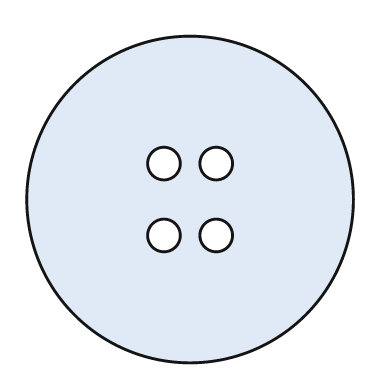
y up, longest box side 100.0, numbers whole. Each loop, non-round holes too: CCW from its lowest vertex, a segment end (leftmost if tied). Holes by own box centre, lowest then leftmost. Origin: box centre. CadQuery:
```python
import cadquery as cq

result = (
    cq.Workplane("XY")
    .moveTo(0.0, 0.0)
    .circle(50.0)
    .moveTo(-8.0, -11.0)
    .circle(5.0)
    .moveTo(8.0, -11.0)
    .circle(5.0)
    .moveTo(-8.0, 11.0)
    .circle(5.0)
    .moveTo(8.0, 11.0)
    .circle(5.0)
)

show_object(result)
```